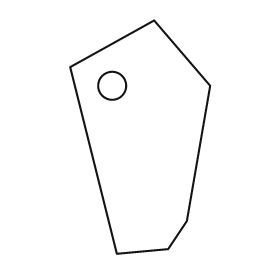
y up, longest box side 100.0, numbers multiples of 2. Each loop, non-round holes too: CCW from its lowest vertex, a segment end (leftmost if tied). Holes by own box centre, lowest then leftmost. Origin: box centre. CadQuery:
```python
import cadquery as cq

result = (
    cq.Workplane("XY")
    .moveTo(-10.0, -50.0)
    .lineTo(12.0, -48.0)
    .lineTo(20.0, -36.0)
    .lineTo(30.0, 22.0)
    .lineTo(6.0, 50.0)
    .lineTo(-30.0, 30.0)
    .close()
    .moveTo(-12.0, 22.0)
    .circle(6.0)
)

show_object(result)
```